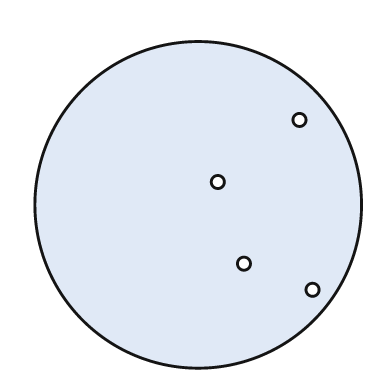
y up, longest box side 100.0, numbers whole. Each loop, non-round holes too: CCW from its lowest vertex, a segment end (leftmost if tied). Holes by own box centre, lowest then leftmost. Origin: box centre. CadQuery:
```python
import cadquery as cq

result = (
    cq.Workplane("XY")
    .moveTo(0.0, 0.0)
    .circle(50.0)
    .moveTo(35.0, -26.0)
    .circle(2.0)
    .moveTo(14.0, -18.0)
    .circle(2.0)
    .moveTo(6.0, 7.0)
    .circle(2.0)
    .moveTo(31.0, 26.0)
    .circle(2.0)
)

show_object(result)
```